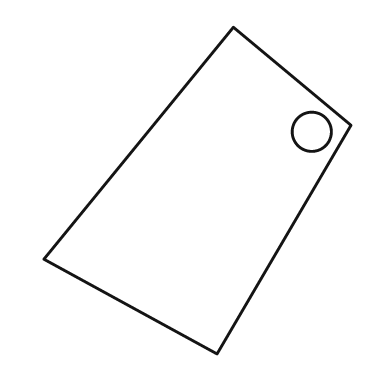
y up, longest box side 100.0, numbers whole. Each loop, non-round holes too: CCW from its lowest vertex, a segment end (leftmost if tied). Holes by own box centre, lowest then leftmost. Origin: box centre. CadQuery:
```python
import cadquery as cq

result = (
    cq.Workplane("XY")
    .moveTo(6.0, -50.0)
    .lineTo(47.0, 20.0)
    .lineTo(11.0, 50.0)
    .lineTo(-47.0, -21.0)
    .close()
    .moveTo(35.0, 18.0)
    .circle(6.0)
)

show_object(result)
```